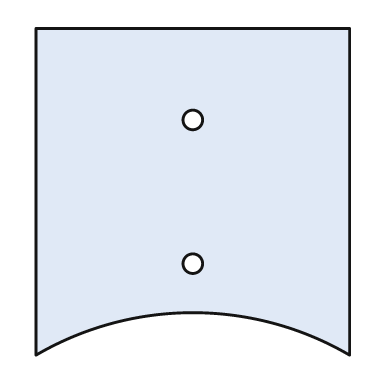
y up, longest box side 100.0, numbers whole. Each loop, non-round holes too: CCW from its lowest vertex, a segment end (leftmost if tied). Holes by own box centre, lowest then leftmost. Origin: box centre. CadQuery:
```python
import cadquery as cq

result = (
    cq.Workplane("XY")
    .moveTo(-48.0, -50.0)
    .threePointArc((0.0, -37.0), (48.0, -50.0))
    .lineTo(48.0, 50.0)
    .lineTo(-48.0, 50.0)
    .close()
    .moveTo(0.0, -22.0)
    .circle(3.0)
    .moveTo(0.0, 22.0)
    .circle(3.0)
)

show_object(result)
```